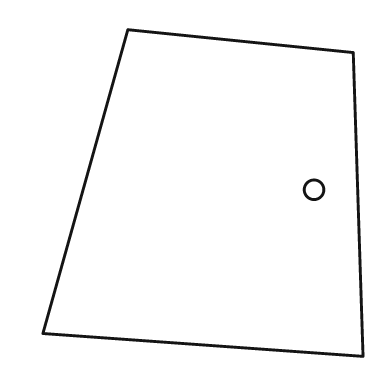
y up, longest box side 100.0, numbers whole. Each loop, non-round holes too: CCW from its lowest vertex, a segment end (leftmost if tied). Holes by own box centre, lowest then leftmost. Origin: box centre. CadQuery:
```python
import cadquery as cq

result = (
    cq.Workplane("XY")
    .moveTo(49.0, -50.0)
    .lineTo(46.0, 43.0)
    .lineTo(-23.0, 50.0)
    .lineTo(-49.0, -43.0)
    .close()
    .moveTo(34.0, 1.0)
    .circle(3.0)
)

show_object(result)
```